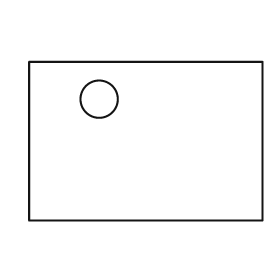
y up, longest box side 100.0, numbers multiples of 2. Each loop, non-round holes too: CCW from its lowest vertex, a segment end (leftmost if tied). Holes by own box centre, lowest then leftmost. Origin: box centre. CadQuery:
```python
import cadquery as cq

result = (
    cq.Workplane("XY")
    .moveTo(-50.0, -34.0)
    .lineTo(50.0, -34.0)
    .lineTo(50.0, 34.0)
    .lineTo(-50.0, 34.0)
    .close()
    .moveTo(-20.0, 18.0)
    .circle(8.0)
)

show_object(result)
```